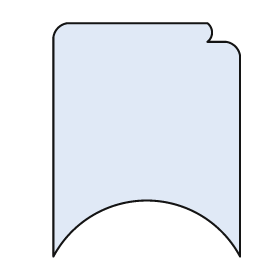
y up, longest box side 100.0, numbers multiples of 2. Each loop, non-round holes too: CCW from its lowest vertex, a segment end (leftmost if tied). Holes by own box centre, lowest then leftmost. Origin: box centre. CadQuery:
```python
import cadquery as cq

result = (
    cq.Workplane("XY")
    .moveTo(-40.0, -50.0)
    .threePointArc((0.0, -26.0), (40.0, -50.0))
    .lineTo(40.0, 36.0)
    .threePointArc((38.0, 40.0), (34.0, 42.0))
    .lineTo(26.0, 42.0)
    .threePointArc((28.0, 46.0), (26.0, 50.0))
    .lineTo(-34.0, 50.0)
    .threePointArc((-38.0, 48.0), (-40.0, 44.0))
    .close()
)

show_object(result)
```